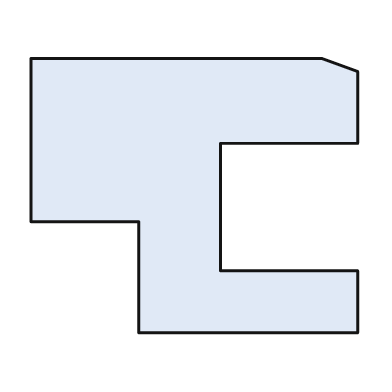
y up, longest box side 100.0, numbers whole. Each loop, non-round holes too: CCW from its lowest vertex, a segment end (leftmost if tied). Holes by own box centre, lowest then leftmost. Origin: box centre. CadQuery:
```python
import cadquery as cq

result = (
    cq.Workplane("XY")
    .moveTo(-17.0, -42.0)
    .lineTo(50.0, -42.0)
    .lineTo(50.0, -23.0)
    .lineTo(8.0, -23.0)
    .lineTo(8.0, 16.0)
    .lineTo(50.0, 16.0)
    .lineTo(50.0, 38.0)
    .lineTo(39.0, 42.0)
    .lineTo(-50.0, 42.0)
    .lineTo(-50.0, -8.0)
    .lineTo(-17.0, -8.0)
    .close()
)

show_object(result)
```